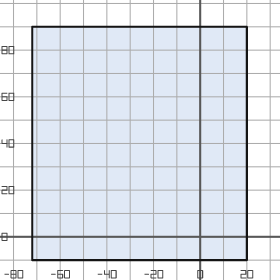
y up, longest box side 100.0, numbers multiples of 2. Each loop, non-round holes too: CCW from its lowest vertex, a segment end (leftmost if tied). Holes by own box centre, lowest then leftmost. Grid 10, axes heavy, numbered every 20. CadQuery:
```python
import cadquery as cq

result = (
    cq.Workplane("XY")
    .moveTo(-72.0, -10.0)
    .lineTo(20.0, -10.0)
    .lineTo(20.0, 90.0)
    .lineTo(-72.0, 90.0)
    .close()
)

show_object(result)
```